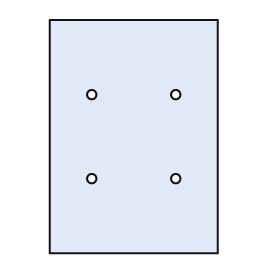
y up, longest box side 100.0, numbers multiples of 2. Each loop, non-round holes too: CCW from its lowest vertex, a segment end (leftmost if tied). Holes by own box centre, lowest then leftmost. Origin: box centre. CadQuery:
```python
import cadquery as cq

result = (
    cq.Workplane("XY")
    .moveTo(-36.0, -50.0)
    .lineTo(36.0, -50.0)
    .lineTo(36.0, 50.0)
    .lineTo(-36.0, 50.0)
    .close()
    .moveTo(-18.0, -18.0)
    .circle(2.0)
    .moveTo(18.0, -18.0)
    .circle(2.0)
    .moveTo(-18.0, 18.0)
    .circle(2.0)
    .moveTo(18.0, 18.0)
    .circle(2.0)
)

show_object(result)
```